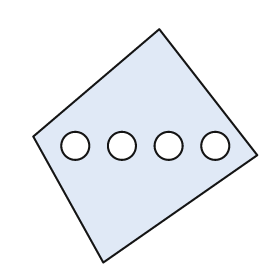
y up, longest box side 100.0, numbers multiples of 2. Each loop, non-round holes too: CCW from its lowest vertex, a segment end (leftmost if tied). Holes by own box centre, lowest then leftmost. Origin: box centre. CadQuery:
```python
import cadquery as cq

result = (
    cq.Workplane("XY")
    .moveTo(-18.0, -50.0)
    .lineTo(48.0, -4.0)
    .lineTo(6.0, 50.0)
    .lineTo(-48.0, 4.0)
    .close()
    .moveTo(-30.0, 0.0)
    .circle(6.0)
    .moveTo(-10.0, 0.0)
    .circle(6.0)
    .moveTo(10.0, 0.0)
    .circle(6.0)
    .moveTo(30.0, 0.0)
    .circle(6.0)
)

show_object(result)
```